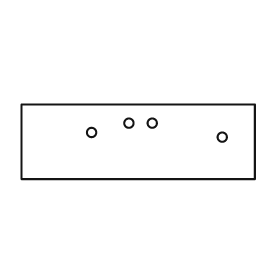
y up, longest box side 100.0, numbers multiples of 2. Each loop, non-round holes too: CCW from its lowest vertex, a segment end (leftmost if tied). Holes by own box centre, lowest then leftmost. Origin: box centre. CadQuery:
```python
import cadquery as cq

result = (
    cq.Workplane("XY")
    .moveTo(-50.0, -16.0)
    .lineTo(50.0, -16.0)
    .lineTo(50.0, 16.0)
    .lineTo(-50.0, 16.0)
    .close()
    .moveTo(36.0, 2.0)
    .circle(2.0)
    .moveTo(-20.0, 4.0)
    .circle(2.0)
    .moveTo(-4.0, 8.0)
    .circle(2.0)
    .moveTo(6.0, 8.0)
    .circle(2.0)
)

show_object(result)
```